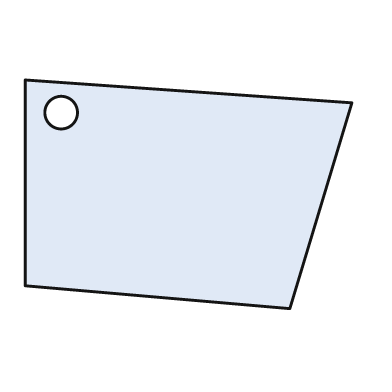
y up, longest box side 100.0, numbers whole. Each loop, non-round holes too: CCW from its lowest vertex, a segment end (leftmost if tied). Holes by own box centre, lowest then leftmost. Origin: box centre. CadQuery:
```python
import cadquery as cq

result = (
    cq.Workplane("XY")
    .moveTo(31.0, -35.0)
    .lineTo(50.0, 28.0)
    .lineTo(-50.0, 35.0)
    .lineTo(-50.0, -28.0)
    .close()
    .moveTo(-39.0, 25.0)
    .circle(5.0)
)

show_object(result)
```